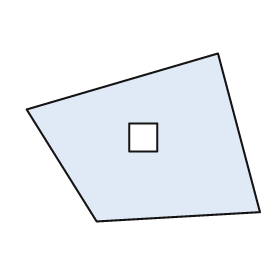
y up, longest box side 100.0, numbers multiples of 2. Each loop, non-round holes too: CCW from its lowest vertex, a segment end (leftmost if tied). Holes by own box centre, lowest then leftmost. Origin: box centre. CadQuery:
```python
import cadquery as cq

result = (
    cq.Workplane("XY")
    .moveTo(-20.0, -36.0)
    .lineTo(50.0, -32.0)
    .lineTo(32.0, 36.0)
    .lineTo(-50.0, 12.0)
    .close()
    .moveTo(-6.0, -6.0)
    .lineTo(6.0, -6.0)
    .lineTo(6.0, 6.0)
    .lineTo(-6.0, 6.0)
    .close()
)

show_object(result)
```